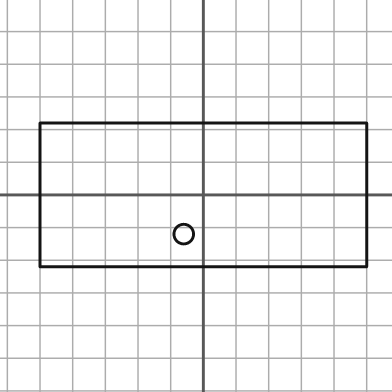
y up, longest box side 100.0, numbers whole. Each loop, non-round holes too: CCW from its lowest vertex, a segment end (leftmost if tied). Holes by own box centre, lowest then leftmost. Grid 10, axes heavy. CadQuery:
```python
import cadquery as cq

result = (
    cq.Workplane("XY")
    .moveTo(-50.0, -22.0)
    .lineTo(50.0, -22.0)
    .lineTo(50.0, 22.0)
    .lineTo(-50.0, 22.0)
    .close()
    .moveTo(-6.0, -12.0)
    .circle(3.0)
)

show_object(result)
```